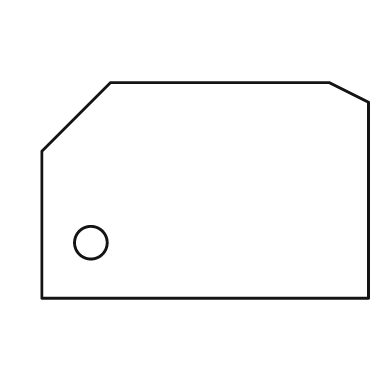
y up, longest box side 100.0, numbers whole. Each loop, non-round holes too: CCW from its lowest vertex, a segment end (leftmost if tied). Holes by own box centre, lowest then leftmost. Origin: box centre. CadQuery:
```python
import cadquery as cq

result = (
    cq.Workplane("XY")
    .moveTo(-50.0, -33.0)
    .lineTo(50.0, -33.0)
    .lineTo(50.0, 27.0)
    .lineTo(38.0, 33.0)
    .lineTo(-29.0, 33.0)
    .lineTo(-50.0, 12.0)
    .close()
    .moveTo(-35.0, -16.0)
    .circle(5.0)
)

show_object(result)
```